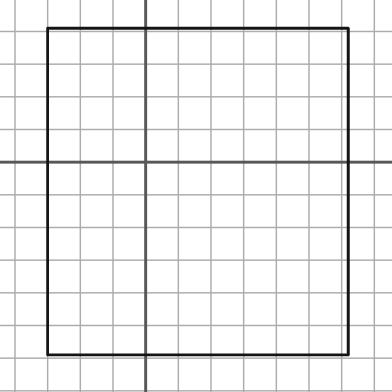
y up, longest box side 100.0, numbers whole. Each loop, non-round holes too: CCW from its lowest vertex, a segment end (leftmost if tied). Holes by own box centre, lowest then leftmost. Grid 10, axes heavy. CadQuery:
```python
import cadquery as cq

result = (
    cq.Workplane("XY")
    .moveTo(-30.0, -59.0)
    .lineTo(62.0, -59.0)
    .lineTo(62.0, 41.0)
    .lineTo(-30.0, 41.0)
    .close()
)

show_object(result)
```